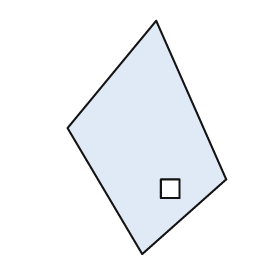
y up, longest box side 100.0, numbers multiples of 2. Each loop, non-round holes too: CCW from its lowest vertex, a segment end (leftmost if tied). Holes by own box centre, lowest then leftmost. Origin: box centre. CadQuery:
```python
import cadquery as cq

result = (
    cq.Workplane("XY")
    .moveTo(-2.0, -50.0)
    .lineTo(34.0, -18.0)
    .lineTo(4.0, 50.0)
    .lineTo(-34.0, 4.0)
    .close()
    .moveTo(6.0, -26.0)
    .lineTo(14.0, -26.0)
    .lineTo(14.0, -18.0)
    .lineTo(6.0, -18.0)
    .close()
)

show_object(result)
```